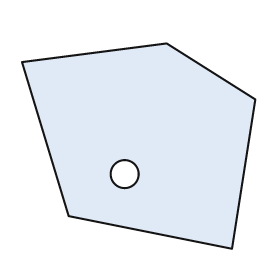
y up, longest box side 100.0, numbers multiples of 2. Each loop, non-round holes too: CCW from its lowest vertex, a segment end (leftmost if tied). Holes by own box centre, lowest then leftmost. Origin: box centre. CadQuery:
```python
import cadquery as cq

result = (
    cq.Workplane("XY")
    .moveTo(40.0, -44.0)
    .lineTo(50.0, 20.0)
    .lineTo(12.0, 44.0)
    .lineTo(-50.0, 36.0)
    .lineTo(-30.0, -30.0)
    .close()
    .moveTo(-6.0, -12.0)
    .circle(6.0)
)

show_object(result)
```